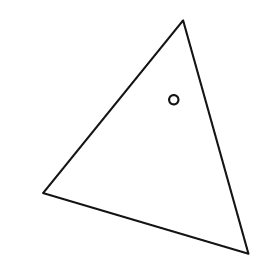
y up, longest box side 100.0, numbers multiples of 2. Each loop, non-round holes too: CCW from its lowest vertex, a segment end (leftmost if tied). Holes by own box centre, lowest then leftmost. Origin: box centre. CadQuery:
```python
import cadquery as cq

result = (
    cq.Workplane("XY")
    .moveTo(44.0, -50.0)
    .lineTo(16.0, 50.0)
    .lineTo(-44.0, -24.0)
    .close()
    .moveTo(12.0, 16.0)
    .circle(2.0)
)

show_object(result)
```